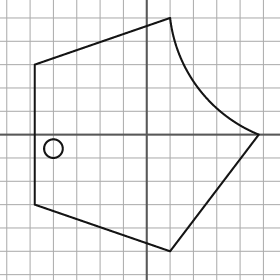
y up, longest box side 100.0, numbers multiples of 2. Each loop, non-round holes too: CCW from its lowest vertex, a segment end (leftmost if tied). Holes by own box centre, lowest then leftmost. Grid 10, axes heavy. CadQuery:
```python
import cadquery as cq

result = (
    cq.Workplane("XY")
    .moveTo(10.0, -50.0)
    .lineTo(48.0, 0.0)
    .threePointArc((22.0, 20.0), (10.0, 50.0))
    .lineTo(-48.0, 30.0)
    .lineTo(-48.0, -30.0)
    .close()
    .moveTo(-40.0, -6.0)
    .circle(4.0)
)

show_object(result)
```